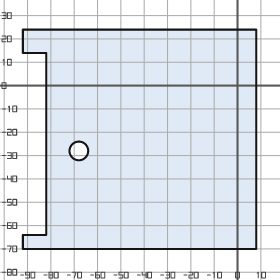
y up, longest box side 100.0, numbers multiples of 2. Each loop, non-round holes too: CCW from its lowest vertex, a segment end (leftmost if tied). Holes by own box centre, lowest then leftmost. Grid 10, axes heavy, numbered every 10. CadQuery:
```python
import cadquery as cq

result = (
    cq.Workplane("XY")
    .moveTo(-92.0, -70.0)
    .lineTo(8.0, -70.0)
    .lineTo(8.0, 24.0)
    .lineTo(-92.0, 24.0)
    .lineTo(-92.0, 14.0)
    .lineTo(-82.0, 14.0)
    .lineTo(-82.0, -64.0)
    .lineTo(-92.0, -64.0)
    .close()
    .moveTo(-68.0, -28.0)
    .circle(4.0)
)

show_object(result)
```